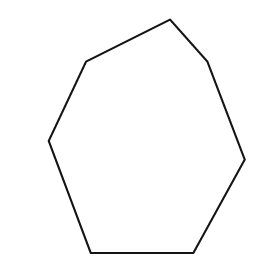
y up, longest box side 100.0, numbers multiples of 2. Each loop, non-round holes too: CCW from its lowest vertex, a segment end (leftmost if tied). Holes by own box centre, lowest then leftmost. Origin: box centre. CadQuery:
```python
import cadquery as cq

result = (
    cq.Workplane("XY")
    .moveTo(-24.0, -50.0)
    .lineTo(20.0, -50.0)
    .lineTo(42.0, -10.0)
    .lineTo(26.0, 32.0)
    .lineTo(10.0, 50.0)
    .lineTo(-26.0, 32.0)
    .lineTo(-42.0, -2.0)
    .close()
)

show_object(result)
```